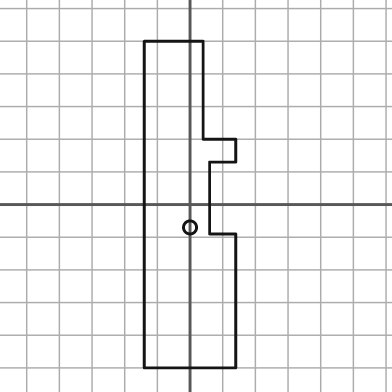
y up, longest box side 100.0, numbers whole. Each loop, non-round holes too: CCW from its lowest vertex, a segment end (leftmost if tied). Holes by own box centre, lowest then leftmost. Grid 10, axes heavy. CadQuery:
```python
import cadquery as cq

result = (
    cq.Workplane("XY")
    .moveTo(-14.0, -50.0)
    .lineTo(14.0, -50.0)
    .lineTo(14.0, -9.0)
    .lineTo(6.0, -9.0)
    .lineTo(6.0, 13.0)
    .lineTo(14.0, 13.0)
    .lineTo(14.0, 20.0)
    .lineTo(4.0, 20.0)
    .lineTo(4.0, 50.0)
    .lineTo(-14.0, 50.0)
    .close()
    .moveTo(0.0, -7.0)
    .circle(2.0)
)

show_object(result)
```